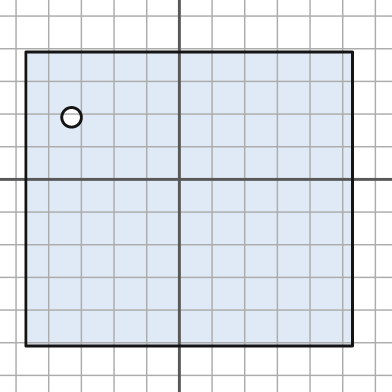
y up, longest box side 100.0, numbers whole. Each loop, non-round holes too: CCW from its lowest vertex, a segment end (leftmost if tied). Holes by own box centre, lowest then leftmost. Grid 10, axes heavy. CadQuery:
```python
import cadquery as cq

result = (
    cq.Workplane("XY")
    .moveTo(-47.0, -51.0)
    .lineTo(53.0, -51.0)
    .lineTo(53.0, 39.0)
    .lineTo(-47.0, 39.0)
    .close()
    .moveTo(-33.0, 19.0)
    .circle(3.0)
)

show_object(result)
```